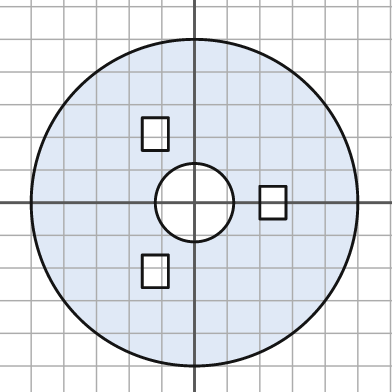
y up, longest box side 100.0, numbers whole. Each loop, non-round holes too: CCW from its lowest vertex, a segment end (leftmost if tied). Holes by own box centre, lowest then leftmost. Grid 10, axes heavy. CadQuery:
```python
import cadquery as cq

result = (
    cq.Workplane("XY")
    .moveTo(0.0, 0.0)
    .circle(50.0)
    .moveTo(-16.0, -26.0)
    .lineTo(-8.0, -26.0)
    .lineTo(-8.0, -16.0)
    .lineTo(-16.0, -16.0)
    .close()
    .moveTo(0.0, 0.0)
    .circle(12.0)
    .moveTo(20.0, -5.0)
    .lineTo(28.0, -5.0)
    .lineTo(28.0, 5.0)
    .lineTo(20.0, 5.0)
    .close()
    .moveTo(-16.0, 16.0)
    .lineTo(-8.0, 16.0)
    .lineTo(-8.0, 26.0)
    .lineTo(-16.0, 26.0)
    .close()
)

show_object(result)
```